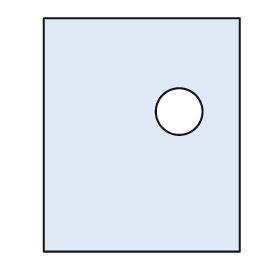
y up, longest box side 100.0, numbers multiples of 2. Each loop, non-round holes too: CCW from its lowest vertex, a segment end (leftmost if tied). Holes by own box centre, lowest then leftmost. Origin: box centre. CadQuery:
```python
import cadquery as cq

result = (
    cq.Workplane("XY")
    .moveTo(-42.0, -50.0)
    .lineTo(42.0, -50.0)
    .lineTo(42.0, 50.0)
    .lineTo(-42.0, 50.0)
    .close()
    .moveTo(16.0, 10.0)
    .circle(10.0)
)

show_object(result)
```